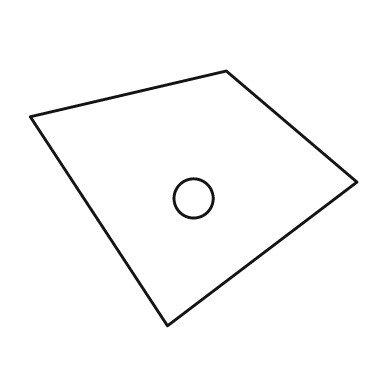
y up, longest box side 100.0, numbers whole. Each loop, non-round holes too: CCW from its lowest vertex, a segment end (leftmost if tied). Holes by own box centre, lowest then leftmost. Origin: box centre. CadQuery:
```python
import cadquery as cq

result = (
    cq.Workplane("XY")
    .moveTo(-8.0, -39.0)
    .lineTo(50.0, 5.0)
    .lineTo(10.0, 39.0)
    .lineTo(-50.0, 25.0)
    .close()
    .moveTo(0.0, 0.0)
    .circle(6.0)
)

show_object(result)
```